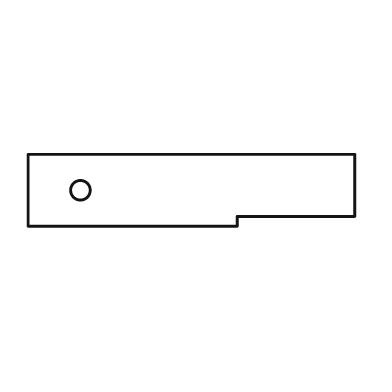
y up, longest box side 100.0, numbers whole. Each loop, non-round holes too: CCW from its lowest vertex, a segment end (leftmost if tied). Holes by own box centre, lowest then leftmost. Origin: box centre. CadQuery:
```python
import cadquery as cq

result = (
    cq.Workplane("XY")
    .moveTo(-50.0, -11.0)
    .lineTo(14.0, -11.0)
    .lineTo(14.0, -8.0)
    .lineTo(50.0, -8.0)
    .lineTo(50.0, 11.0)
    .lineTo(-50.0, 11.0)
    .close()
    .moveTo(-34.0, 0.0)
    .circle(3.0)
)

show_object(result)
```